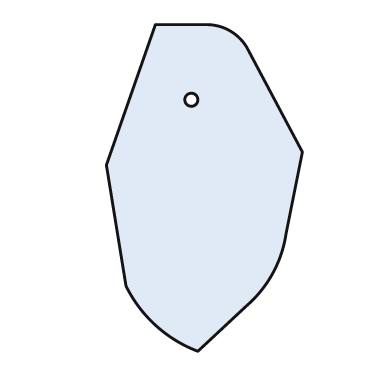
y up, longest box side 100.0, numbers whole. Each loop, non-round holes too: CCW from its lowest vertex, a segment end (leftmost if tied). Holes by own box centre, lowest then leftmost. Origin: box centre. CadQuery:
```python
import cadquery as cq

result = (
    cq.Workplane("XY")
    .moveTo(-2.0, -50.0)
    .lineTo(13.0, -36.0)
    .threePointArc((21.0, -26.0), (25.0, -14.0))
    .lineTo(30.0, 11.0)
    .lineTo(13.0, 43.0)
    .threePointArc((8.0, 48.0), (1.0, 50.0))
    .lineTo(-15.0, 50.0)
    .lineTo(-30.0, 7.0)
    .lineTo(-24.0, -30.0)
    .threePointArc((-15.0, -42.0), (-2.0, -50.0))
    .close()
    .moveTo(-4.0, 27.0)
    .circle(2.0)
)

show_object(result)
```